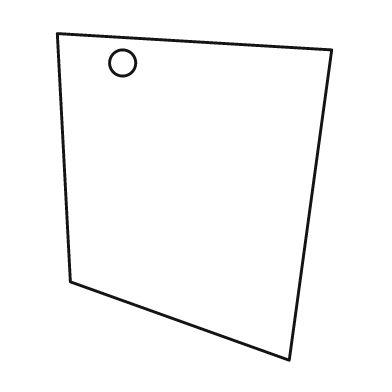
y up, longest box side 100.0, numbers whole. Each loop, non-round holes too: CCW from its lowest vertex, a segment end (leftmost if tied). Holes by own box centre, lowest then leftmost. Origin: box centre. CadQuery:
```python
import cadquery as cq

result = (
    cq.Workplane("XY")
    .moveTo(29.0, -50.0)
    .lineTo(42.0, 45.0)
    .lineTo(-42.0, 50.0)
    .lineTo(-38.0, -26.0)
    .close()
    .moveTo(-22.0, 41.0)
    .circle(4.0)
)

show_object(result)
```